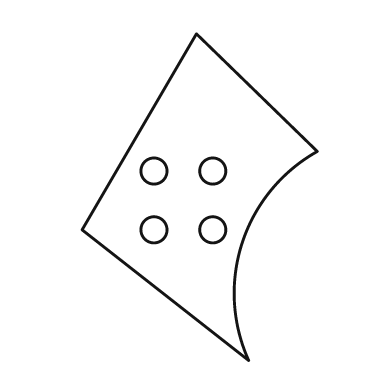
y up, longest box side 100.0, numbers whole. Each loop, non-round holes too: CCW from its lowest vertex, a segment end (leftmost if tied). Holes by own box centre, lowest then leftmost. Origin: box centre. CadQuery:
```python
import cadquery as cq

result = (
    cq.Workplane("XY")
    .moveTo(15.0, -50.0)
    .threePointArc((13.0, -14.0), (36.0, 14.0))
    .lineTo(-1.0, 50.0)
    .lineTo(-36.0, -10.0)
    .close()
    .moveTo(-14.0, -10.0)
    .circle(4.0)
    .moveTo(4.0, -10.0)
    .circle(4.0)
    .moveTo(-14.0, 8.0)
    .circle(4.0)
    .moveTo(4.0, 8.0)
    .circle(4.0)
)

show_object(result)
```